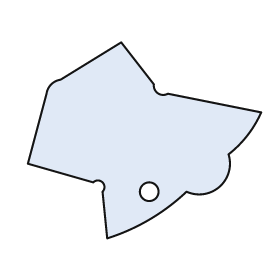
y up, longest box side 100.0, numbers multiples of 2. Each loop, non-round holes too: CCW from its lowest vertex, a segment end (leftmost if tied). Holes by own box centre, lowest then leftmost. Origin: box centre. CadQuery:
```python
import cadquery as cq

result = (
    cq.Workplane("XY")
    .moveTo(-16.0, -42.0)
    .threePointArc((2.0, -34.0), (18.0, -22.0))
    .threePointArc((32.0, -20.0), (36.0, -6.0))
    .threePointArc((44.0, 2.0), (50.0, 12.0))
    .lineTo(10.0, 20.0)
    .threePointArc((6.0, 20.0), (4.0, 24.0))
    .lineTo(-10.0, 42.0)
    .lineTo(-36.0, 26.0)
    .threePointArc((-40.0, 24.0), (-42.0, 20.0))
    .lineTo(-50.0, -10.0)
    .lineTo(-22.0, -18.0)
    .threePointArc((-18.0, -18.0), (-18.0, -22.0))
    .close()
    .moveTo(2.0, -22.0)
    .circle(4.0)
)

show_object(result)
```